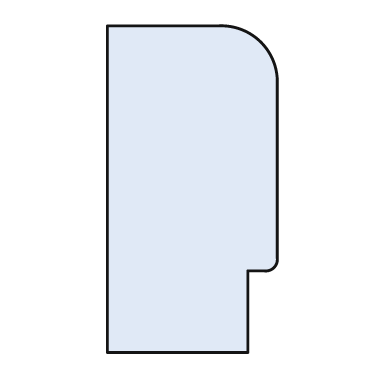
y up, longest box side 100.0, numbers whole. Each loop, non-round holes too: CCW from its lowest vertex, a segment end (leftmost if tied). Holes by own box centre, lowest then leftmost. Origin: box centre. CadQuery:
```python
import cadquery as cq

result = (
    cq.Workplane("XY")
    .moveTo(-26.0, -50.0)
    .lineTo(17.0, -50.0)
    .lineTo(17.0, -25.0)
    .lineTo(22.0, -25.0)
    .threePointArc((25.0, -24.0), (26.0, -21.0))
    .lineTo(26.0, 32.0)
    .threePointArc((21.0, 45.0), (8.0, 50.0))
    .lineTo(-26.0, 50.0)
    .close()
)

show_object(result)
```